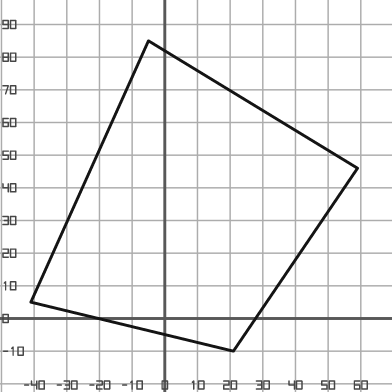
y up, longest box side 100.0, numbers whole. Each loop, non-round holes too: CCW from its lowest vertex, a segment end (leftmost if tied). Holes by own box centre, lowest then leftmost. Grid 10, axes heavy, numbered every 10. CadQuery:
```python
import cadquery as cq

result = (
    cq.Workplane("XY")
    .moveTo(21.0, -10.0)
    .lineTo(59.0, 46.0)
    .lineTo(-5.0, 85.0)
    .lineTo(-41.0, 5.0)
    .close()
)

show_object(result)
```